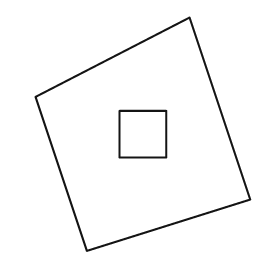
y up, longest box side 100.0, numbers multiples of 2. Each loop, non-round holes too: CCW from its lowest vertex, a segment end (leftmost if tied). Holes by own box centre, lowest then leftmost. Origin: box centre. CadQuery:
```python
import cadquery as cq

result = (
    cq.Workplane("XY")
    .moveTo(-24.0, -50.0)
    .lineTo(46.0, -28.0)
    .lineTo(20.0, 50.0)
    .lineTo(-46.0, 16.0)
    .close()
    .moveTo(-10.0, -10.0)
    .lineTo(10.0, -10.0)
    .lineTo(10.0, 10.0)
    .lineTo(-10.0, 10.0)
    .close()
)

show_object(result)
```